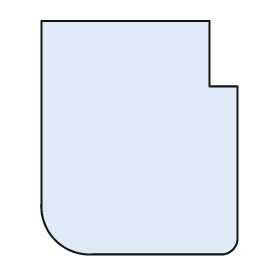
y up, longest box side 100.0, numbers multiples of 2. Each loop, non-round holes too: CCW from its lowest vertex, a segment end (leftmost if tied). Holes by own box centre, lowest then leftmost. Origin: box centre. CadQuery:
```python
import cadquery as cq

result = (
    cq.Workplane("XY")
    .moveTo(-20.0, -50.0)
    .lineTo(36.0, -50.0)
    .threePointArc((40.0, -48.0), (42.0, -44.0))
    .lineTo(42.0, 22.0)
    .lineTo(30.0, 22.0)
    .lineTo(30.0, 50.0)
    .lineTo(-42.0, 50.0)
    .lineTo(-42.0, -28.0)
    .threePointArc((-36.0, -44.0), (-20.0, -50.0))
    .close()
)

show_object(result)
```